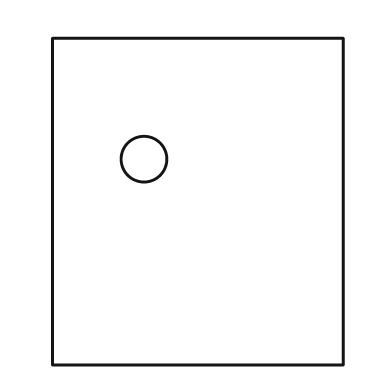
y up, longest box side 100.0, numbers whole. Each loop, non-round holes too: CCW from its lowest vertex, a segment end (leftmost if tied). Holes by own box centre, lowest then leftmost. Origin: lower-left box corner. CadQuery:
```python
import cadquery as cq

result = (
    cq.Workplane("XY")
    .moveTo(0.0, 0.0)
    .lineTo(89.0, 0.0)
    .lineTo(89.0, 100.0)
    .lineTo(0.0, 100.0)
    .close()
    .moveTo(28.0, 63.0)
    .circle(7.0)
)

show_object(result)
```